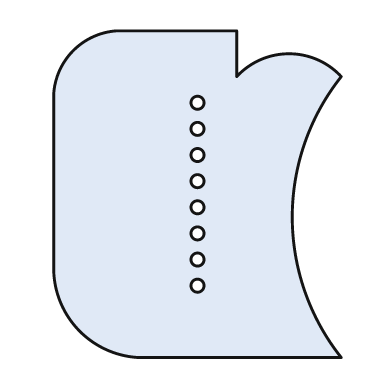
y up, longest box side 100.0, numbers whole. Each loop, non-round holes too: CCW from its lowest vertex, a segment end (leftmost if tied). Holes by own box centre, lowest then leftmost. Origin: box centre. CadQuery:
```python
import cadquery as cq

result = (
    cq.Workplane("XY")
    .moveTo(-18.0, -50.0)
    .lineTo(44.0, -50.0)
    .threePointArc((29.0, -7.0), (44.0, 36.0))
    .threePointArc((28.0, 43.0), (12.0, 36.0))
    .lineTo(12.0, 50.0)
    .lineTo(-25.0, 50.0)
    .threePointArc((-38.0, 44.0), (-44.0, 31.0))
    .lineTo(-44.0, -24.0)
    .threePointArc((-36.0, -42.0), (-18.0, -50.0))
    .close()
    .moveTo(0.0, -28.0)
    .circle(2.0)
    .moveTo(0.0, -20.0)
    .circle(2.0)
    .moveTo(0.0, -12.0)
    .circle(2.0)
    .moveTo(0.0, -4.0)
    .circle(2.0)
    .moveTo(0.0, 4.0)
    .circle(2.0)
    .moveTo(0.0, 12.0)
    .circle(2.0)
    .moveTo(0.0, 20.0)
    .circle(2.0)
    .moveTo(0.0, 28.0)
    .circle(2.0)
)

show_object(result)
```